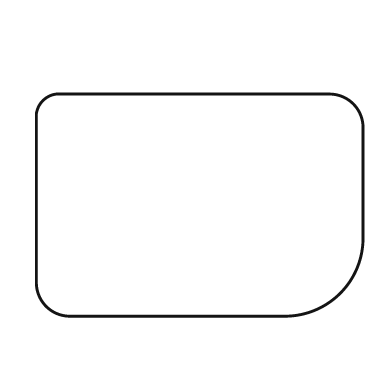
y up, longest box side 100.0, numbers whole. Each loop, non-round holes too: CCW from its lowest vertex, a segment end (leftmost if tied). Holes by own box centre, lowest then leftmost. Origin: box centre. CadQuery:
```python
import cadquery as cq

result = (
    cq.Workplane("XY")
    .moveTo(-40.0, -34.0)
    .lineTo(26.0, -34.0)
    .threePointArc((43.0, -27.0), (50.0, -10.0))
    .lineTo(50.0, 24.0)
    .threePointArc((47.0, 31.0), (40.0, 34.0))
    .lineTo(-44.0, 34.0)
    .threePointArc((-48.0, 32.0), (-50.0, 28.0))
    .lineTo(-50.0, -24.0)
    .threePointArc((-47.0, -31.0), (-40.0, -34.0))
    .close()
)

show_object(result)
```